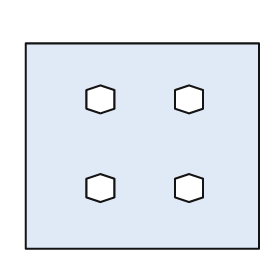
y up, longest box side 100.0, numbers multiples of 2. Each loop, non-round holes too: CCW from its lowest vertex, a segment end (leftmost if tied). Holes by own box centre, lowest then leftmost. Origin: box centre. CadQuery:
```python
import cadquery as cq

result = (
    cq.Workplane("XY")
    .moveTo(-50.0, -44.0)
    .lineTo(50.0, -44.0)
    .lineTo(50.0, 44.0)
    .lineTo(-50.0, 44.0)
    .close()
    .moveTo(-18.0, -24.0)
    .lineTo(-12.0, -22.0)
    .lineTo(-12.0, -14.0)
    .lineTo(-18.0, -12.0)
    .lineTo(-24.0, -14.0)
    .lineTo(-24.0, -22.0)
    .close()
    .moveTo(20.0, -24.0)
    .lineTo(26.0, -22.0)
    .lineTo(26.0, -14.0)
    .lineTo(20.0, -12.0)
    .lineTo(14.0, -14.0)
    .lineTo(14.0, -22.0)
    .close()
    .moveTo(-18.0, 14.0)
    .lineTo(-12.0, 16.0)
    .lineTo(-12.0, 24.0)
    .lineTo(-18.0, 26.0)
    .lineTo(-24.0, 24.0)
    .lineTo(-24.0, 16.0)
    .close()
    .moveTo(20.0, 14.0)
    .lineTo(26.0, 16.0)
    .lineTo(26.0, 24.0)
    .lineTo(20.0, 26.0)
    .lineTo(14.0, 24.0)
    .lineTo(14.0, 16.0)
    .close()
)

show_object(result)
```